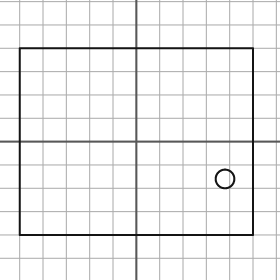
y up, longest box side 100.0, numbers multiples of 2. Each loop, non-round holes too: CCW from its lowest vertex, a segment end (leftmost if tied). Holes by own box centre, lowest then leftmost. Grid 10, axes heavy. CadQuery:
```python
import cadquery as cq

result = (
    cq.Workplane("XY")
    .moveTo(-50.0, -40.0)
    .lineTo(50.0, -40.0)
    .lineTo(50.0, 40.0)
    .lineTo(-50.0, 40.0)
    .close()
    .moveTo(38.0, -16.0)
    .circle(4.0)
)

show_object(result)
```